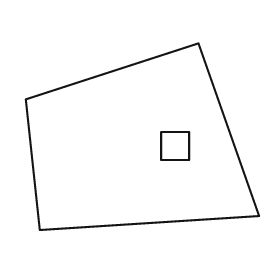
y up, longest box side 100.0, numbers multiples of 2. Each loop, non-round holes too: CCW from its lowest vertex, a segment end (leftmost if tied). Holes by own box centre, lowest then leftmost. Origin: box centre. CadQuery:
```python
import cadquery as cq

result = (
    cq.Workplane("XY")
    .moveTo(-44.0, -40.0)
    .lineTo(50.0, -34.0)
    .lineTo(24.0, 40.0)
    .lineTo(-50.0, 16.0)
    .close()
    .moveTo(8.0, -10.0)
    .lineTo(20.0, -10.0)
    .lineTo(20.0, 2.0)
    .lineTo(8.0, 2.0)
    .close()
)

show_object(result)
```